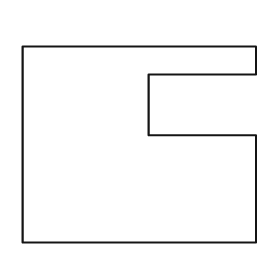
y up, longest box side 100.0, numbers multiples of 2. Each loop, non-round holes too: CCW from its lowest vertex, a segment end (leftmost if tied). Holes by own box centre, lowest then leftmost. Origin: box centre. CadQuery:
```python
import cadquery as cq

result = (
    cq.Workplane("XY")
    .moveTo(-50.0, -42.0)
    .lineTo(50.0, -42.0)
    .lineTo(50.0, 4.0)
    .lineTo(4.0, 4.0)
    .lineTo(4.0, 30.0)
    .lineTo(50.0, 30.0)
    .lineTo(50.0, 42.0)
    .lineTo(-50.0, 42.0)
    .close()
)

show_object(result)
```